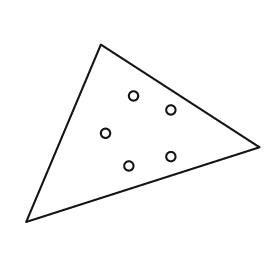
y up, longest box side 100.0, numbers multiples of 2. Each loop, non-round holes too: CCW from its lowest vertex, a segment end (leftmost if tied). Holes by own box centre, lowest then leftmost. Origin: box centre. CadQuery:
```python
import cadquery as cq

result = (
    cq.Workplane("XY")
    .moveTo(-50.0, -38.0)
    .lineTo(50.0, -6.0)
    .lineTo(-18.0, 38.0)
    .close()
    .moveTo(-6.0, -14.0)
    .circle(2.0)
    .moveTo(12.0, -10.0)
    .circle(2.0)
    .moveTo(-16.0, 0.0)
    .circle(2.0)
    .moveTo(12.0, 10.0)
    .circle(2.0)
    .moveTo(-4.0, 16.0)
    .circle(2.0)
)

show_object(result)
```